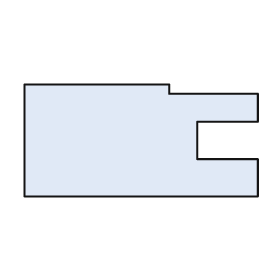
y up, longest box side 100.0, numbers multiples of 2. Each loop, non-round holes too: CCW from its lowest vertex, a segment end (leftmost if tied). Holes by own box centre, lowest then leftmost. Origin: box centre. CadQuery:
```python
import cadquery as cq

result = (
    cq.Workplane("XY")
    .moveTo(-50.0, -24.0)
    .lineTo(50.0, -24.0)
    .lineTo(50.0, -8.0)
    .lineTo(24.0, -8.0)
    .lineTo(24.0, 8.0)
    .lineTo(50.0, 8.0)
    .lineTo(50.0, 20.0)
    .lineTo(12.0, 20.0)
    .lineTo(12.0, 24.0)
    .lineTo(-50.0, 24.0)
    .close()
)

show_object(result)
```